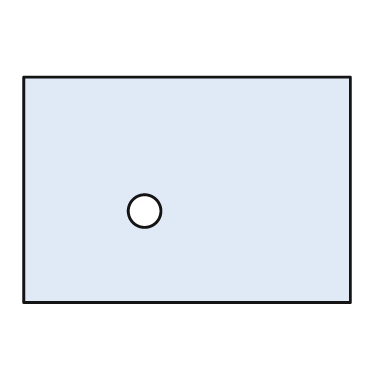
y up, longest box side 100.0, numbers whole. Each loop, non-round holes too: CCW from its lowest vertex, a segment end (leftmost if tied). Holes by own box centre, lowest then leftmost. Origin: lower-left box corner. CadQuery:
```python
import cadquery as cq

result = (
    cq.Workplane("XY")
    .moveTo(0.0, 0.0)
    .lineTo(100.0, 0.0)
    .lineTo(100.0, 69.0)
    .lineTo(0.0, 69.0)
    .close()
    .moveTo(37.0, 28.0)
    .circle(5.0)
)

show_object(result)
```